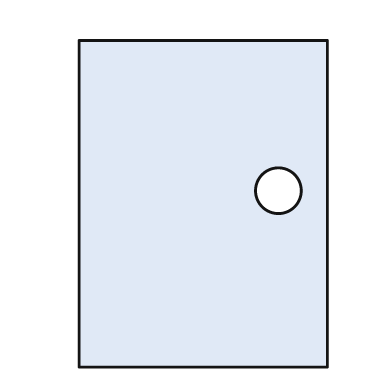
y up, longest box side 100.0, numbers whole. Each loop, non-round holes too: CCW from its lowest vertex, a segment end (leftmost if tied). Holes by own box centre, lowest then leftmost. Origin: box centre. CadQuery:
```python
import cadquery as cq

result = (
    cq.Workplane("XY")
    .moveTo(-38.0, -50.0)
    .lineTo(38.0, -50.0)
    .lineTo(38.0, 50.0)
    .lineTo(-38.0, 50.0)
    .close()
    .moveTo(23.0, 4.0)
    .circle(7.0)
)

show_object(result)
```